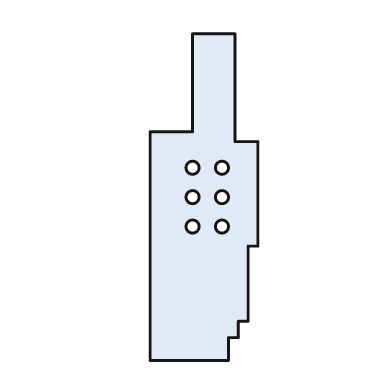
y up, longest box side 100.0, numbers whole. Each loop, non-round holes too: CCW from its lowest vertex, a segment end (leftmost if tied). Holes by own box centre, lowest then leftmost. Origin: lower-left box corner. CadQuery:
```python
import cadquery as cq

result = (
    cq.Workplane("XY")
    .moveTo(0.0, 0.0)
    .lineTo(24.0, 0.0)
    .lineTo(24.0, 7.0)
    .lineTo(27.0, 7.0)
    .lineTo(27.0, 12.0)
    .lineTo(30.0, 12.0)
    .lineTo(30.0, 35.0)
    .lineTo(33.0, 35.0)
    .lineTo(33.0, 67.0)
    .lineTo(26.0, 67.0)
    .lineTo(26.0, 100.0)
    .lineTo(13.0, 100.0)
    .lineTo(13.0, 70.0)
    .lineTo(0.0, 70.0)
    .close()
    .moveTo(13.0, 41.0)
    .circle(2.0)
    .moveTo(22.0, 41.0)
    .circle(2.0)
    .moveTo(13.0, 50.0)
    .circle(2.0)
    .moveTo(22.0, 50.0)
    .circle(2.0)
    .moveTo(13.0, 59.0)
    .circle(2.0)
    .moveTo(22.0, 59.0)
    .circle(2.0)
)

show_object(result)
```